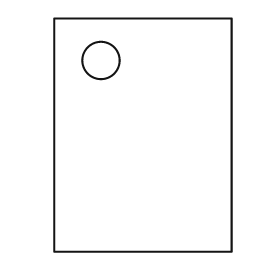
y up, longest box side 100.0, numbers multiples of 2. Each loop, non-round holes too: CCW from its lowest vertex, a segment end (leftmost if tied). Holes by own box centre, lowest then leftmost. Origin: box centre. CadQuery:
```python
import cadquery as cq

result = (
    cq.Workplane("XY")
    .moveTo(-38.0, -50.0)
    .lineTo(38.0, -50.0)
    .lineTo(38.0, 50.0)
    .lineTo(-38.0, 50.0)
    .close()
    .moveTo(-18.0, 32.0)
    .circle(8.0)
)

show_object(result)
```